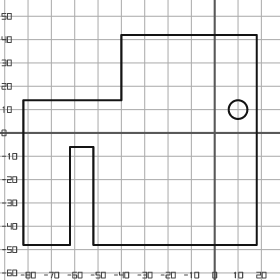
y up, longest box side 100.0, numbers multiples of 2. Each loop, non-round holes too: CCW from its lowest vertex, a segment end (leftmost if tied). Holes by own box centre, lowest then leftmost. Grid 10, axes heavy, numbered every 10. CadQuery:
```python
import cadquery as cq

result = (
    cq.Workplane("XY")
    .moveTo(-82.0, -48.0)
    .lineTo(-62.0, -48.0)
    .lineTo(-62.0, -6.0)
    .lineTo(-52.0, -6.0)
    .lineTo(-52.0, -48.0)
    .lineTo(18.0, -48.0)
    .lineTo(18.0, 42.0)
    .lineTo(-40.0, 42.0)
    .lineTo(-40.0, 14.0)
    .lineTo(-82.0, 14.0)
    .close()
    .moveTo(10.0, 10.0)
    .circle(4.0)
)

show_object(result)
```